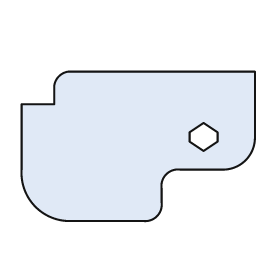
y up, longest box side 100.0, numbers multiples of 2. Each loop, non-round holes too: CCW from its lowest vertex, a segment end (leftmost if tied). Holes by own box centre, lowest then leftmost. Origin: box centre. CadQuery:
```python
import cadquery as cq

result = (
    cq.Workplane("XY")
    .moveTo(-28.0, -32.0)
    .lineTo(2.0, -32.0)
    .threePointArc((8.0, -30.0), (10.0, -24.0))
    .lineTo(10.0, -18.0)
    .threePointArc((12.0, -12.0), (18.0, -10.0))
    .lineTo(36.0, -10.0)
    .threePointArc((46.0, -6.0), (50.0, 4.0))
    .lineTo(50.0, 32.0)
    .lineTo(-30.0, 32.0)
    .threePointArc((-34.0, 30.0), (-36.0, 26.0))
    .lineTo(-36.0, 18.0)
    .lineTo(-50.0, 18.0)
    .lineTo(-50.0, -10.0)
    .threePointArc((-44.0, -26.0), (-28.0, -32.0))
    .close()
    .moveTo(28.0, -2.0)
    .lineTo(34.0, 2.0)
    .lineTo(34.0, 6.0)
    .lineTo(28.0, 10.0)
    .lineTo(22.0, 6.0)
    .lineTo(22.0, 2.0)
    .close()
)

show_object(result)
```